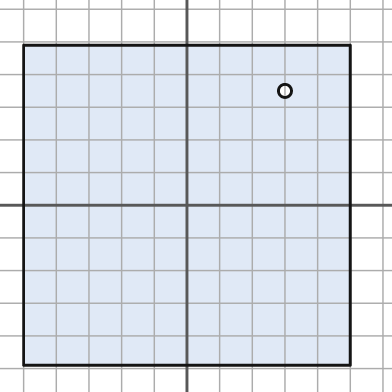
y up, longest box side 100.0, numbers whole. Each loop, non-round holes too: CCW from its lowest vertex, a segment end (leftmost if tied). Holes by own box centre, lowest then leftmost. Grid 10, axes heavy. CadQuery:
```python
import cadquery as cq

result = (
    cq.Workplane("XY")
    .moveTo(-50.0, -49.0)
    .lineTo(50.0, -49.0)
    .lineTo(50.0, 49.0)
    .lineTo(-50.0, 49.0)
    .close()
    .moveTo(30.0, 35.0)
    .circle(2.0)
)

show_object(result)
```